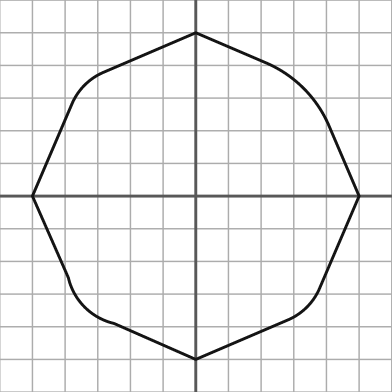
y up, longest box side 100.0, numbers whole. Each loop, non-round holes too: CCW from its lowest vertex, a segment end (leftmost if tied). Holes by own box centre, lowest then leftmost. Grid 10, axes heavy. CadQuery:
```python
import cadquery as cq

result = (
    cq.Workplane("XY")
    .moveTo(0.0, -50.0)
    .lineTo(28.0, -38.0)
    .threePointArc((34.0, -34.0), (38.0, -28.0))
    .lineTo(50.0, 0.0)
    .lineTo(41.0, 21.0)
    .threePointArc((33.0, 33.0), (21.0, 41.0))
    .lineTo(0.0, 50.0)
    .lineTo(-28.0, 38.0)
    .threePointArc((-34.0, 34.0), (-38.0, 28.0))
    .lineTo(-50.0, 0.0)
    .lineTo(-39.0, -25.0)
    .threePointArc((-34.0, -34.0), (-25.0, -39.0))
    .close()
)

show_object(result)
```